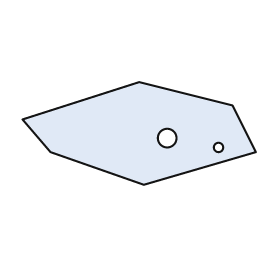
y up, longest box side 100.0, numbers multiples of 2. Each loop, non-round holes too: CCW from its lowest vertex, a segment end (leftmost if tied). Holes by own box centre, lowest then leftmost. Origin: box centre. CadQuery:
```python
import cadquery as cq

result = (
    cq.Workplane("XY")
    .moveTo(2.0, -22.0)
    .lineTo(50.0, -8.0)
    .lineTo(40.0, 12.0)
    .lineTo(0.0, 22.0)
    .lineTo(-50.0, 6.0)
    .lineTo(-38.0, -8.0)
    .close()
    .moveTo(34.0, -6.0)
    .circle(2.0)
    .moveTo(12.0, -2.0)
    .circle(4.0)
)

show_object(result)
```